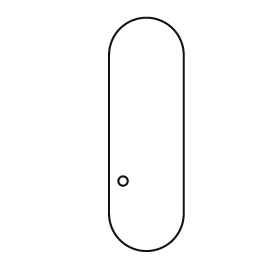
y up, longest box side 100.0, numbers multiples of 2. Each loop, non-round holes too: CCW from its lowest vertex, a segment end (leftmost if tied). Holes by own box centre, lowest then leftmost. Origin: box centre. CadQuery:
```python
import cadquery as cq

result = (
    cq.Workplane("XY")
    .moveTo(-16.0, -34.0)
    .threePointArc((0.0, -50.0), (16.0, -34.0))
    .lineTo(16.0, 34.0)
    .threePointArc((0.0, 50.0), (-16.0, 34.0))
    .close()
    .moveTo(-10.0, -20.0)
    .circle(2.0)
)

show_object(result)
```